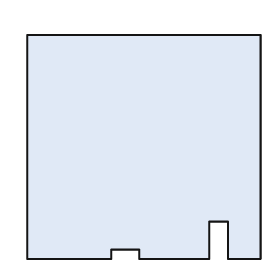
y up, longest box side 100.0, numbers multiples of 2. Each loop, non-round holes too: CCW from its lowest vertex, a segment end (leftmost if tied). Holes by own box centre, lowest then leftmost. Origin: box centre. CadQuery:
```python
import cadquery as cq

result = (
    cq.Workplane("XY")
    .moveTo(-50.0, -48.0)
    .lineTo(-14.0, -48.0)
    .lineTo(-14.0, -44.0)
    .lineTo(-2.0, -44.0)
    .lineTo(-2.0, -48.0)
    .lineTo(28.0, -48.0)
    .lineTo(28.0, -32.0)
    .lineTo(36.0, -32.0)
    .lineTo(36.0, -48.0)
    .lineTo(50.0, -48.0)
    .lineTo(50.0, 48.0)
    .lineTo(-50.0, 48.0)
    .close()
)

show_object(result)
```